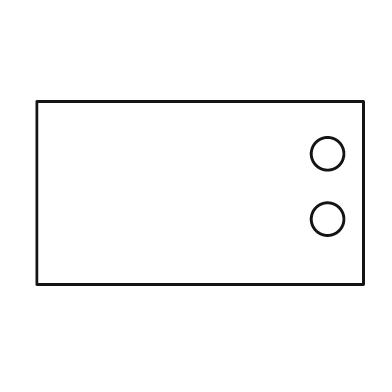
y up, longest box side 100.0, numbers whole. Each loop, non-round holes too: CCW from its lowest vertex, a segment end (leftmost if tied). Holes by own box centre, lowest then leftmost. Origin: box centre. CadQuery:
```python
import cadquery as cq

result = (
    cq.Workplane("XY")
    .moveTo(-50.0, -28.0)
    .lineTo(50.0, -28.0)
    .lineTo(50.0, 28.0)
    .lineTo(-50.0, 28.0)
    .close()
    .moveTo(39.0, -8.0)
    .circle(5.0)
    .moveTo(39.0, 12.0)
    .circle(5.0)
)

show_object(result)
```